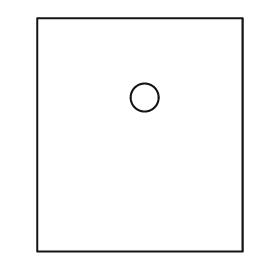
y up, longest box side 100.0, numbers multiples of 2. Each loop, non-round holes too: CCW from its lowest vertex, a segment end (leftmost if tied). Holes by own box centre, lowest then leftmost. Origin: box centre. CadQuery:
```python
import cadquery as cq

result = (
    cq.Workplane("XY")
    .moveTo(-44.0, -50.0)
    .lineTo(44.0, -50.0)
    .lineTo(44.0, 50.0)
    .lineTo(-44.0, 50.0)
    .close()
    .moveTo(2.0, 16.0)
    .circle(6.0)
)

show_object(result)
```